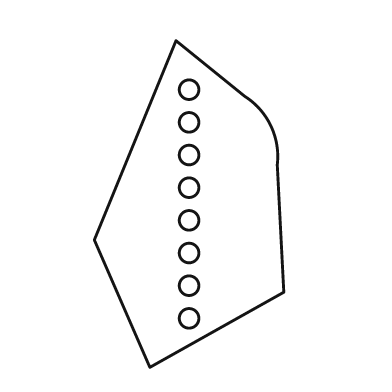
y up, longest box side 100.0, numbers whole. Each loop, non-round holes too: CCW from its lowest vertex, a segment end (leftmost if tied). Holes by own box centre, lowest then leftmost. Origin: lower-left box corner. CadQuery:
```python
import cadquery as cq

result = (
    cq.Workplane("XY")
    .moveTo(17.0, 0.0)
    .lineTo(58.0, 23.0)
    .lineTo(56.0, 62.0)
    .threePointArc((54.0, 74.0), (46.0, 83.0))
    .lineTo(25.0, 100.0)
    .lineTo(0.0, 39.0)
    .close()
    .moveTo(29.0, 15.0)
    .circle(3.0)
    .moveTo(29.0, 25.0)
    .circle(3.0)
    .moveTo(29.0, 35.0)
    .circle(3.0)
    .moveTo(29.0, 45.0)
    .circle(3.0)
    .moveTo(29.0, 55.0)
    .circle(3.0)
    .moveTo(29.0, 65.0)
    .circle(3.0)
    .moveTo(29.0, 75.0)
    .circle(3.0)
    .moveTo(29.0, 85.0)
    .circle(3.0)
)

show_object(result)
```